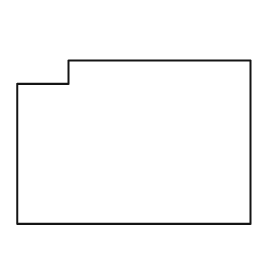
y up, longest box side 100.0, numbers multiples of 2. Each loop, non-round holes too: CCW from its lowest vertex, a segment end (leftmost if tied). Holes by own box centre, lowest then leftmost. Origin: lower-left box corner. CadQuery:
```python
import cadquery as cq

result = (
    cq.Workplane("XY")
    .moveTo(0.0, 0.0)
    .lineTo(100.0, 0.0)
    .lineTo(100.0, 70.0)
    .lineTo(22.0, 70.0)
    .lineTo(22.0, 60.0)
    .lineTo(0.0, 60.0)
    .close()
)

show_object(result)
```